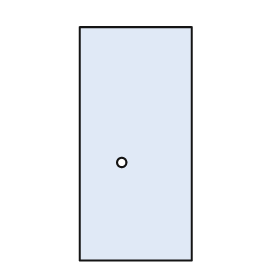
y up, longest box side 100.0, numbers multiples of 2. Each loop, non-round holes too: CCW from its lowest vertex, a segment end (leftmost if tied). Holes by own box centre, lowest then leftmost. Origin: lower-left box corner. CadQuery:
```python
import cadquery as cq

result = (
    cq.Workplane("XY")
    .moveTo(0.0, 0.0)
    .lineTo(48.0, 0.0)
    .lineTo(48.0, 100.0)
    .lineTo(0.0, 100.0)
    .close()
    .moveTo(18.0, 42.0)
    .circle(2.0)
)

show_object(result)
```